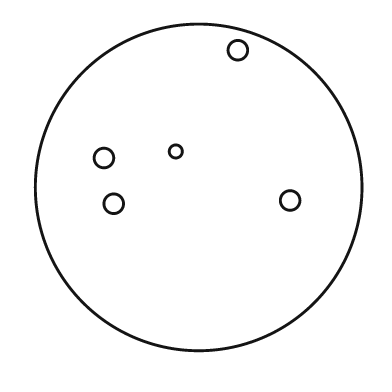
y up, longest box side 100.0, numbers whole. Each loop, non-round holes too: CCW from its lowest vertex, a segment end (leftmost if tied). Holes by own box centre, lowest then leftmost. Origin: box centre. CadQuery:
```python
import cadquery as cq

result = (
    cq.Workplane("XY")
    .moveTo(0.0, 0.0)
    .circle(50.0)
    .moveTo(-26.0, -5.0)
    .circle(3.0)
    .moveTo(28.0, -4.0)
    .circle(3.0)
    .moveTo(-29.0, 9.0)
    .circle(3.0)
    .moveTo(-7.0, 11.0)
    .circle(2.0)
    .moveTo(12.0, 42.0)
    .circle(3.0)
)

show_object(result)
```